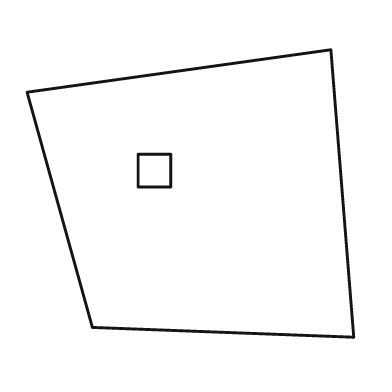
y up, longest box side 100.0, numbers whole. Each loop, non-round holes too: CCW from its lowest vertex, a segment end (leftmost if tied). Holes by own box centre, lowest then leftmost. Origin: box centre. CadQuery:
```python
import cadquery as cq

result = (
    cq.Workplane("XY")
    .moveTo(50.0, -44.0)
    .lineTo(43.0, 44.0)
    .lineTo(-50.0, 31.0)
    .lineTo(-30.0, -41.0)
    .close()
    .moveTo(-16.0, 2.0)
    .lineTo(-6.0, 2.0)
    .lineTo(-6.0, 12.0)
    .lineTo(-16.0, 12.0)
    .close()
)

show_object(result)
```